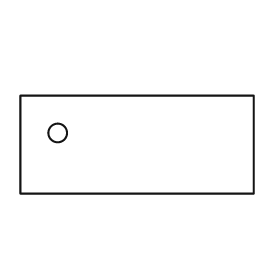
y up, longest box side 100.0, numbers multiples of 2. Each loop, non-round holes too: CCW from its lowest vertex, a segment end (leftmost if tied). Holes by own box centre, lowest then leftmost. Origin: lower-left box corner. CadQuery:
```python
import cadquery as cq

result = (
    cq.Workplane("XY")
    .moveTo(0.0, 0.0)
    .lineTo(100.0, 0.0)
    .lineTo(100.0, 42.0)
    .lineTo(0.0, 42.0)
    .close()
    .moveTo(16.0, 26.0)
    .circle(4.0)
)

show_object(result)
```